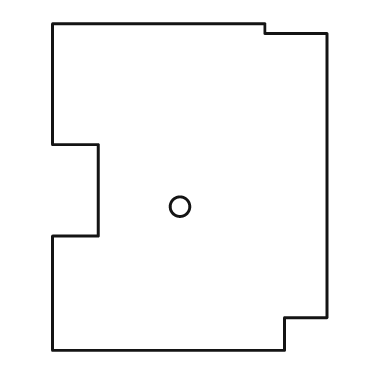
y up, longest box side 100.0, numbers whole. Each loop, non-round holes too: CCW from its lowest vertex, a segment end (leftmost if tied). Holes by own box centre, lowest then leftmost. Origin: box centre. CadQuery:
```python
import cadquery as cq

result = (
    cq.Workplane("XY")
    .moveTo(-42.0, -50.0)
    .lineTo(29.0, -50.0)
    .lineTo(29.0, -40.0)
    .lineTo(42.0, -40.0)
    .lineTo(42.0, 47.0)
    .lineTo(23.0, 47.0)
    .lineTo(23.0, 50.0)
    .lineTo(-42.0, 50.0)
    .lineTo(-42.0, 13.0)
    .lineTo(-28.0, 13.0)
    .lineTo(-28.0, -15.0)
    .lineTo(-42.0, -15.0)
    .close()
    .moveTo(-3.0, -6.0)
    .circle(3.0)
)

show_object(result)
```